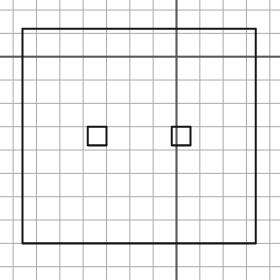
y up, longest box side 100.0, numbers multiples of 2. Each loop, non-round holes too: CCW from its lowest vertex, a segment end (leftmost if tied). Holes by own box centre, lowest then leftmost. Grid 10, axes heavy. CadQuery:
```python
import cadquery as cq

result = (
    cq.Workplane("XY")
    .moveTo(-66.0, -80.0)
    .lineTo(34.0, -80.0)
    .lineTo(34.0, 12.0)
    .lineTo(-66.0, 12.0)
    .close()
    .moveTo(-38.0, -38.0)
    .lineTo(-30.0, -38.0)
    .lineTo(-30.0, -30.0)
    .lineTo(-38.0, -30.0)
    .close()
    .moveTo(-2.0, -38.0)
    .lineTo(6.0, -38.0)
    .lineTo(6.0, -30.0)
    .lineTo(-2.0, -30.0)
    .close()
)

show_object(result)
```